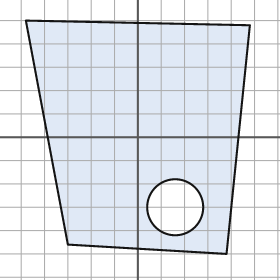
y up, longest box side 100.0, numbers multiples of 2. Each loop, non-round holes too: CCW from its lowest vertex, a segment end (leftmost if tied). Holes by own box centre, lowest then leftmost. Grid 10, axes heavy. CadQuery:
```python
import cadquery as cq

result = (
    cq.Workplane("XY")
    .moveTo(38.0, -50.0)
    .lineTo(48.0, 48.0)
    .lineTo(-48.0, 50.0)
    .lineTo(-30.0, -46.0)
    .close()
    .moveTo(16.0, -30.0)
    .circle(12.0)
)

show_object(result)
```